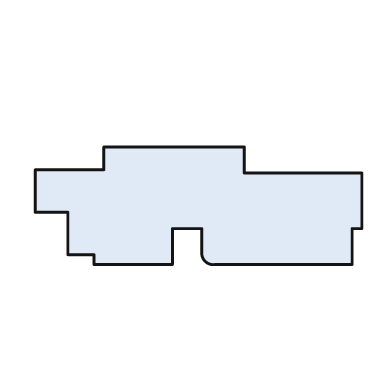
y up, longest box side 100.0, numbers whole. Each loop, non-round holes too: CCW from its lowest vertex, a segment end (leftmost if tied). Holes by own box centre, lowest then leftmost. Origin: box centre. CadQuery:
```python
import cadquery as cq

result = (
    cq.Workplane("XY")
    .moveTo(-32.0, -18.0)
    .lineTo(-8.0, -18.0)
    .lineTo(-8.0, -7.0)
    .lineTo(1.0, -7.0)
    .lineTo(1.0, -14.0)
    .threePointArc((2.0, -17.0), (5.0, -18.0))
    .lineTo(47.0, -18.0)
    .lineTo(47.0, -7.0)
    .lineTo(50.0, -7.0)
    .lineTo(50.0, 10.0)
    .lineTo(14.0, 10.0)
    .lineTo(14.0, 18.0)
    .lineTo(-29.0, 18.0)
    .lineTo(-29.0, 11.0)
    .lineTo(-50.0, 11.0)
    .lineTo(-50.0, -2.0)
    .lineTo(-40.0, -2.0)
    .lineTo(-40.0, -15.0)
    .lineTo(-32.0, -15.0)
    .close()
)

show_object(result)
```